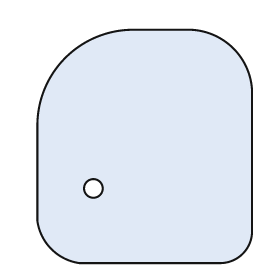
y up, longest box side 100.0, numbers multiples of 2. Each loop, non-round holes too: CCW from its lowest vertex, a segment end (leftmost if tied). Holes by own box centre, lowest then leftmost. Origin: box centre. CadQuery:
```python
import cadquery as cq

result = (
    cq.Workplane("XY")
    .moveTo(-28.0, -50.0)
    .lineTo(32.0, -50.0)
    .threePointArc((42.0, -46.0), (46.0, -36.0))
    .lineTo(46.0, 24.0)
    .threePointArc((38.0, 42.0), (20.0, 50.0))
    .lineTo(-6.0, 50.0)
    .threePointArc((-34.0, 38.0), (-46.0, 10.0))
    .lineTo(-46.0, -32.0)
    .threePointArc((-40.0, -44.0), (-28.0, -50.0))
    .close()
    .moveTo(-22.0, -18.0)
    .circle(4.0)
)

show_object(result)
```